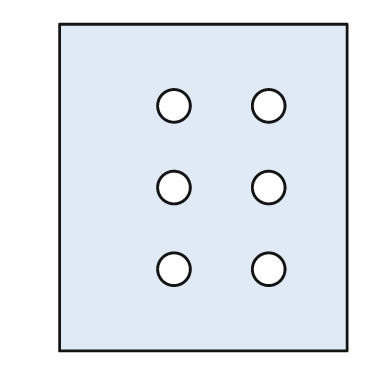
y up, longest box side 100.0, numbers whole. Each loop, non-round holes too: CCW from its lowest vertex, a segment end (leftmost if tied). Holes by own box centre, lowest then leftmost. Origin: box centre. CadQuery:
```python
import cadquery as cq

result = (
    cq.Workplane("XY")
    .moveTo(-44.0, -50.0)
    .lineTo(44.0, -50.0)
    .lineTo(44.0, 50.0)
    .lineTo(-44.0, 50.0)
    .close()
    .moveTo(-9.0, -25.0)
    .circle(5.0)
    .moveTo(20.0, -25.0)
    .circle(5.0)
    .moveTo(-9.0, 0.0)
    .circle(5.0)
    .moveTo(20.0, 0.0)
    .circle(5.0)
    .moveTo(-9.0, 25.0)
    .circle(5.0)
    .moveTo(20.0, 25.0)
    .circle(5.0)
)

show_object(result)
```